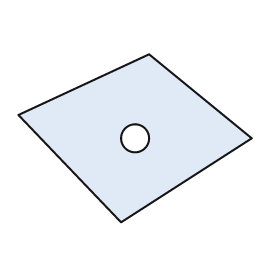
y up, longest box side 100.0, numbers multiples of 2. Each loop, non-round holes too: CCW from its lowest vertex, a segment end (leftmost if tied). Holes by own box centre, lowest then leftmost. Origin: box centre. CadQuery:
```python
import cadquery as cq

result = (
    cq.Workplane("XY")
    .moveTo(-6.0, -36.0)
    .lineTo(50.0, 0.0)
    .lineTo(6.0, 36.0)
    .lineTo(-50.0, 10.0)
    .close()
    .moveTo(0.0, 0.0)
    .circle(6.0)
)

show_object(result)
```